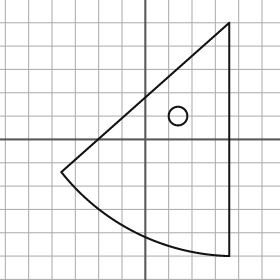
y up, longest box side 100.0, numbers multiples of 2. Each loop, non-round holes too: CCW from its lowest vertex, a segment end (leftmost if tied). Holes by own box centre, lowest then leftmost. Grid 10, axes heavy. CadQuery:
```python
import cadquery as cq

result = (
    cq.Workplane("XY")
    .moveTo(36.0, -50.0)
    .lineTo(36.0, 50.0)
    .lineTo(-36.0, -14.0)
    .threePointArc((-4.0, -40.0), (36.0, -50.0))
    .close()
    .moveTo(14.0, 10.0)
    .circle(4.0)
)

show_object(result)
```